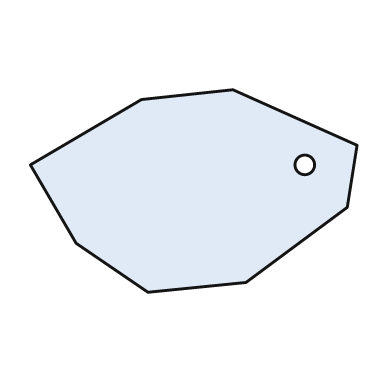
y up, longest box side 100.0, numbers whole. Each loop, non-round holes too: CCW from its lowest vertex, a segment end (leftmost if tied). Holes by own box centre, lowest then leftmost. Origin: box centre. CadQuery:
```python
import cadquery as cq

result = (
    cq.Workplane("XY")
    .moveTo(-14.0, -31.0)
    .lineTo(16.0, -28.0)
    .lineTo(47.0, -5.0)
    .lineTo(50.0, 14.0)
    .lineTo(12.0, 31.0)
    .lineTo(-16.0, 28.0)
    .lineTo(-50.0, 8.0)
    .lineTo(-36.0, -16.0)
    .close()
    .moveTo(34.0, 8.0)
    .circle(3.0)
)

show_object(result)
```